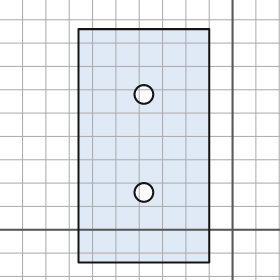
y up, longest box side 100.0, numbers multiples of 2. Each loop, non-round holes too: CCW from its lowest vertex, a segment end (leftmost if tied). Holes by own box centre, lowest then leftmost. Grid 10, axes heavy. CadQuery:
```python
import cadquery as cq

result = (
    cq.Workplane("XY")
    .moveTo(-66.0, -14.0)
    .lineTo(-10.0, -14.0)
    .lineTo(-10.0, 86.0)
    .lineTo(-66.0, 86.0)
    .close()
    .moveTo(-38.0, 16.0)
    .circle(4.0)
    .moveTo(-38.0, 58.0)
    .circle(4.0)
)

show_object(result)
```